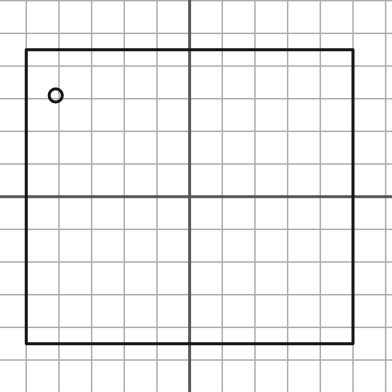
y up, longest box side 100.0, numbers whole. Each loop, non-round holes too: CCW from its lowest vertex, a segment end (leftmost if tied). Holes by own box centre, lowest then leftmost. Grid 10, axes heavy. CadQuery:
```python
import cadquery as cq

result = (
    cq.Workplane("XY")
    .moveTo(-50.0, -45.0)
    .lineTo(50.0, -45.0)
    .lineTo(50.0, 45.0)
    .lineTo(-50.0, 45.0)
    .close()
    .moveTo(-41.0, 31.0)
    .circle(2.0)
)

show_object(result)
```